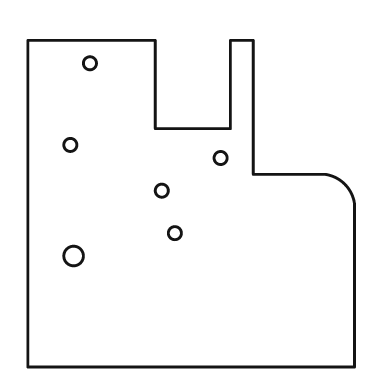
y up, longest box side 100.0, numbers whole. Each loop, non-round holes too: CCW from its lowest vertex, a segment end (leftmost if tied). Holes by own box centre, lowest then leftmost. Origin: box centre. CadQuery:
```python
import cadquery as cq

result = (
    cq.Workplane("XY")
    .moveTo(-50.0, -50.0)
    .lineTo(50.0, -50.0)
    .lineTo(50.0, 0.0)
    .threePointArc((47.0, 6.0), (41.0, 9.0))
    .lineTo(19.0, 9.0)
    .lineTo(19.0, 50.0)
    .lineTo(12.0, 50.0)
    .lineTo(12.0, 23.0)
    .lineTo(-11.0, 23.0)
    .lineTo(-11.0, 50.0)
    .lineTo(-50.0, 50.0)
    .close()
    .moveTo(-36.0, -16.0)
    .circle(3.0)
    .moveTo(-5.0, -9.0)
    .circle(2.0)
    .moveTo(-9.0, 4.0)
    .circle(2.0)
    .moveTo(9.0, 14.0)
    .circle(2.0)
    .moveTo(-37.0, 18.0)
    .circle(2.0)
    .moveTo(-31.0, 43.0)
    .circle(2.0)
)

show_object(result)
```